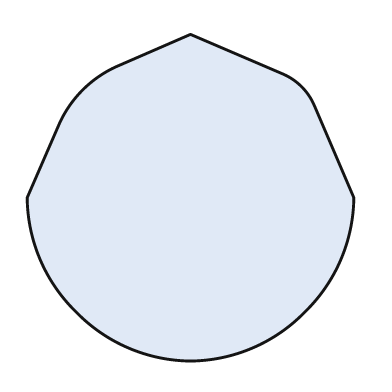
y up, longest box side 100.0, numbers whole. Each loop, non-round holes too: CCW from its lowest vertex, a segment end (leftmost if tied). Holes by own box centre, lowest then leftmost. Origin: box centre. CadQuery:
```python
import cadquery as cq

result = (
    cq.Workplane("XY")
    .moveTo(0.0, -50.0)
    .threePointArc((19.0, -46.0), (35.0, -35.0))
    .threePointArc((46.0, -19.0), (50.0, 0.0))
    .lineTo(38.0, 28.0)
    .threePointArc((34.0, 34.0), (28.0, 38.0))
    .lineTo(0.0, 50.0)
    .lineTo(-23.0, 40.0)
    .threePointArc((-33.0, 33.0), (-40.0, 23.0))
    .lineTo(-50.0, 0.0)
    .threePointArc((-46.0, -19.0), (-35.0, -35.0))
    .threePointArc((-19.0, -46.0), (0.0, -50.0))
    .close()
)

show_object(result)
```